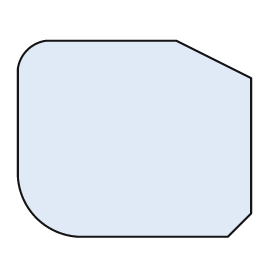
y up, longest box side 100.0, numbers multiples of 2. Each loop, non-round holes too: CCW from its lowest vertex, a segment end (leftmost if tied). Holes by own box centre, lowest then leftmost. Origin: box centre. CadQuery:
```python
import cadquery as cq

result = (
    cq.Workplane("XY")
    .moveTo(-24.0, -42.0)
    .lineTo(40.0, -42.0)
    .lineTo(50.0, -32.0)
    .lineTo(50.0, 26.0)
    .lineTo(18.0, 42.0)
    .lineTo(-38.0, 42.0)
    .threePointArc((-46.0, 38.0), (-50.0, 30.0))
    .lineTo(-50.0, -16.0)
    .threePointArc((-42.0, -34.0), (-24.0, -42.0))
    .close()
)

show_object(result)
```